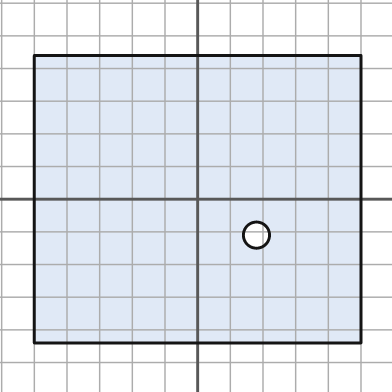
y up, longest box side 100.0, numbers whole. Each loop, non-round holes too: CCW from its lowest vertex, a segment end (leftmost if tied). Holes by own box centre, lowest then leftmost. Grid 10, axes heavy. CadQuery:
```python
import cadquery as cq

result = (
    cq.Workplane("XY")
    .moveTo(-50.0, -44.0)
    .lineTo(50.0, -44.0)
    .lineTo(50.0, 44.0)
    .lineTo(-50.0, 44.0)
    .close()
    .moveTo(18.0, -11.0)
    .circle(4.0)
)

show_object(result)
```